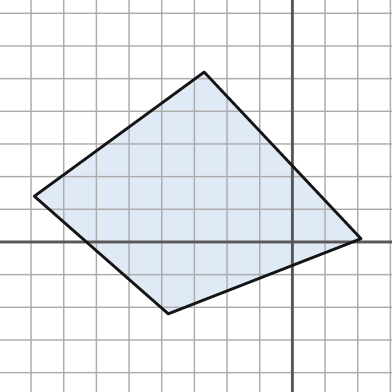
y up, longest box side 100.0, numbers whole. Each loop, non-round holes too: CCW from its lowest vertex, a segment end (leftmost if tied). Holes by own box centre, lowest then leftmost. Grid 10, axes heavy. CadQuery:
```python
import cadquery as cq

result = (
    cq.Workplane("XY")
    .moveTo(-38.0, -22.0)
    .lineTo(21.0, 1.0)
    .lineTo(-27.0, 52.0)
    .lineTo(-79.0, 14.0)
    .close()
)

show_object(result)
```